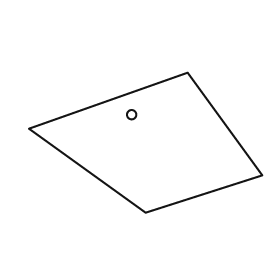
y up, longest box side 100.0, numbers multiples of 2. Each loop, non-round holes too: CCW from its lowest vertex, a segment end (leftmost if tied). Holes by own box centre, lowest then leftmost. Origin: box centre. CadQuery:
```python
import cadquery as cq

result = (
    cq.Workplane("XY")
    .moveTo(0.0, -30.0)
    .lineTo(50.0, -14.0)
    .lineTo(18.0, 30.0)
    .lineTo(-50.0, 6.0)
    .close()
    .moveTo(-6.0, 12.0)
    .circle(2.0)
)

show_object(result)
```